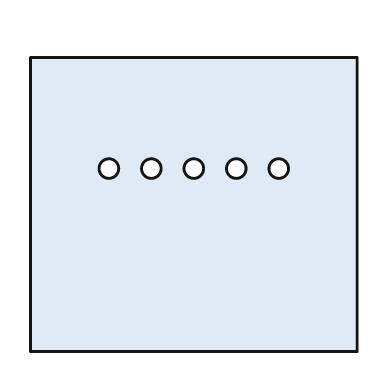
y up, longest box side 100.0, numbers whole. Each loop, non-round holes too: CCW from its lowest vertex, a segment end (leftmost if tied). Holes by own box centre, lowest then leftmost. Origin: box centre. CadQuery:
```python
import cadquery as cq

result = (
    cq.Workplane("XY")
    .moveTo(-50.0, -45.0)
    .lineTo(50.0, -45.0)
    .lineTo(50.0, 45.0)
    .lineTo(-50.0, 45.0)
    .close()
    .moveTo(-26.0, 11.0)
    .circle(3.0)
    .moveTo(-13.0, 11.0)
    .circle(3.0)
    .moveTo(0.0, 11.0)
    .circle(3.0)
    .moveTo(13.0, 11.0)
    .circle(3.0)
    .moveTo(26.0, 11.0)
    .circle(3.0)
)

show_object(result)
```